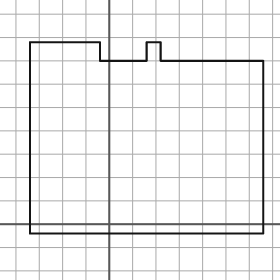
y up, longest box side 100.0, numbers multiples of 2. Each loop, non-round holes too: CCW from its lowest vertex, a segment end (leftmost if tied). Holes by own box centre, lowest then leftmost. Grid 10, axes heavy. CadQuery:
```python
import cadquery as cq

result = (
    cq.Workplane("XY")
    .moveTo(-34.0, -4.0)
    .lineTo(66.0, -4.0)
    .lineTo(66.0, 70.0)
    .lineTo(22.0, 70.0)
    .lineTo(22.0, 78.0)
    .lineTo(16.0, 78.0)
    .lineTo(16.0, 70.0)
    .lineTo(-4.0, 70.0)
    .lineTo(-4.0, 78.0)
    .lineTo(-34.0, 78.0)
    .close()
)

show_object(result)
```